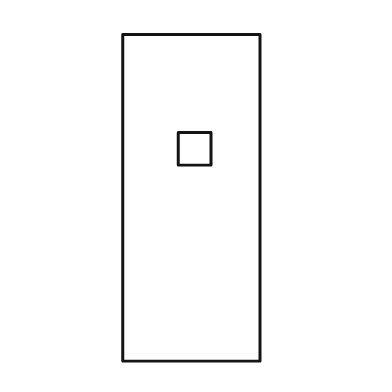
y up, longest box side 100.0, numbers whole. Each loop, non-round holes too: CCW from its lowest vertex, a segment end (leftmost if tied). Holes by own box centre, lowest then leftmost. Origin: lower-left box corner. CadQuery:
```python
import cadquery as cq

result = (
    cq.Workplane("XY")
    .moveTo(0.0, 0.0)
    .lineTo(42.0, 0.0)
    .lineTo(42.0, 100.0)
    .lineTo(0.0, 100.0)
    .close()
    .moveTo(17.0, 60.0)
    .lineTo(27.0, 60.0)
    .lineTo(27.0, 70.0)
    .lineTo(17.0, 70.0)
    .close()
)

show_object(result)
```